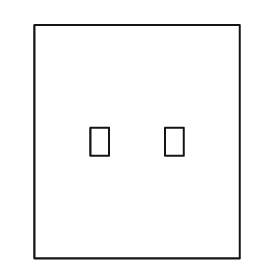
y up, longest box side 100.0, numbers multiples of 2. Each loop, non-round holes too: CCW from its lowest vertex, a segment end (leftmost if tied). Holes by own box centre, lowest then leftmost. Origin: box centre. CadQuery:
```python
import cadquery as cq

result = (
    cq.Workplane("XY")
    .moveTo(-44.0, -50.0)
    .lineTo(44.0, -50.0)
    .lineTo(44.0, 50.0)
    .lineTo(-44.0, 50.0)
    .close()
    .moveTo(-20.0, -6.0)
    .lineTo(-12.0, -6.0)
    .lineTo(-12.0, 6.0)
    .lineTo(-20.0, 6.0)
    .close()
    .moveTo(12.0, -6.0)
    .lineTo(20.0, -6.0)
    .lineTo(20.0, 6.0)
    .lineTo(12.0, 6.0)
    .close()
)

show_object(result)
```